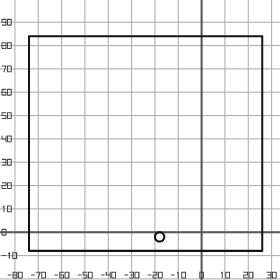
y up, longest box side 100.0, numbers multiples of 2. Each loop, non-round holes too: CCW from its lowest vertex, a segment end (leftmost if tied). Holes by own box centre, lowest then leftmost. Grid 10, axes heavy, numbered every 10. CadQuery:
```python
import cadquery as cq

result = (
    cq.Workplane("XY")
    .moveTo(-74.0, -8.0)
    .lineTo(26.0, -8.0)
    .lineTo(26.0, 84.0)
    .lineTo(-74.0, 84.0)
    .close()
    .moveTo(-18.0, -2.0)
    .circle(2.0)
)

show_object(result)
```